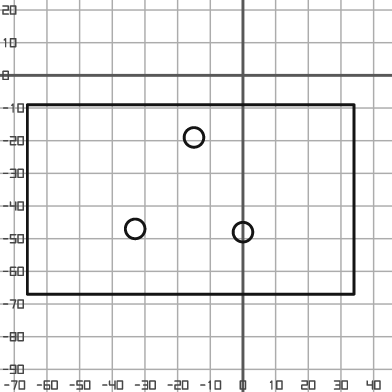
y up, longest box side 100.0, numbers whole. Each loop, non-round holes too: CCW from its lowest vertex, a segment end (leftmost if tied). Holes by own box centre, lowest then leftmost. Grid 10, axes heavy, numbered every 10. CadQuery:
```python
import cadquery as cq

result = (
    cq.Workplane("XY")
    .moveTo(-66.0, -67.0)
    .lineTo(34.0, -67.0)
    .lineTo(34.0, -9.0)
    .lineTo(-66.0, -9.0)
    .close()
    .moveTo(0.0, -48.0)
    .circle(3.0)
    .moveTo(-33.0, -47.0)
    .circle(3.0)
    .moveTo(-15.0, -19.0)
    .circle(3.0)
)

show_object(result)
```